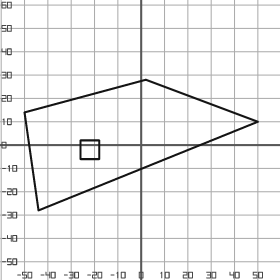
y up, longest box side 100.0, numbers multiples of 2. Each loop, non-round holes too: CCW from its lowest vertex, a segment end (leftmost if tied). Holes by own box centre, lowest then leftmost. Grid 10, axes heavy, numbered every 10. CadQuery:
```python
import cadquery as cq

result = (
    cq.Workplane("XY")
    .moveTo(-44.0, -28.0)
    .lineTo(50.0, 10.0)
    .lineTo(2.0, 28.0)
    .lineTo(-50.0, 14.0)
    .close()
    .moveTo(-26.0, -6.0)
    .lineTo(-18.0, -6.0)
    .lineTo(-18.0, 2.0)
    .lineTo(-26.0, 2.0)
    .close()
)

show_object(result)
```